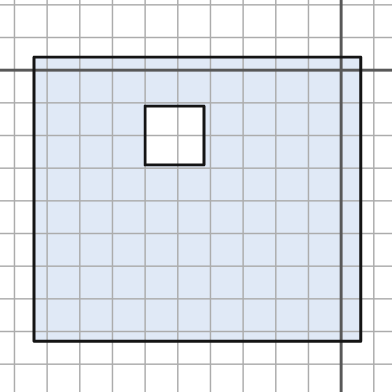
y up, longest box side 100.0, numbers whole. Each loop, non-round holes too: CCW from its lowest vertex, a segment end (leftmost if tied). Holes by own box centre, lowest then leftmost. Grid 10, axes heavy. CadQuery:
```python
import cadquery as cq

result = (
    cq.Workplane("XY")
    .moveTo(-94.0, -83.0)
    .lineTo(6.0, -83.0)
    .lineTo(6.0, 4.0)
    .lineTo(-94.0, 4.0)
    .close()
    .moveTo(-60.0, -29.0)
    .lineTo(-42.0, -29.0)
    .lineTo(-42.0, -11.0)
    .lineTo(-60.0, -11.0)
    .close()
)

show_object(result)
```